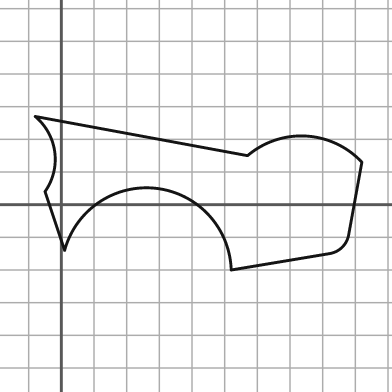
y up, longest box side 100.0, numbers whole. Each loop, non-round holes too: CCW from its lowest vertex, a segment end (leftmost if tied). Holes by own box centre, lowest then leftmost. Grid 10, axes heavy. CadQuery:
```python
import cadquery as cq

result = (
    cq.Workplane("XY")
    .moveTo(52.0, -20.0)
    .lineTo(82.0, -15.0)
    .threePointArc((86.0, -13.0), (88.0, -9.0))
    .lineTo(92.0, 13.0)
    .threePointArc((75.0, 21.0), (57.0, 15.0))
    .lineTo(-8.0, 27.0)
    .threePointArc((-2.0, 16.0), (-5.0, 4.0))
    .lineTo(1.0, -14.0)
    .threePointArc((29.0, 5.0), (52.0, -20.0))
    .close()
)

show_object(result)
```